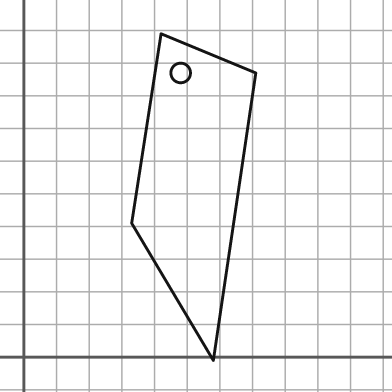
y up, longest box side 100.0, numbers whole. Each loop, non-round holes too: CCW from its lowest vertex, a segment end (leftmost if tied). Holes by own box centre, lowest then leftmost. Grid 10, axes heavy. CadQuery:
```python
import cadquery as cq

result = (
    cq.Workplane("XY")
    .moveTo(58.0, -1.0)
    .lineTo(71.0, 87.0)
    .lineTo(42.0, 99.0)
    .lineTo(33.0, 41.0)
    .close()
    .moveTo(48.0, 87.0)
    .circle(3.0)
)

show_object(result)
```